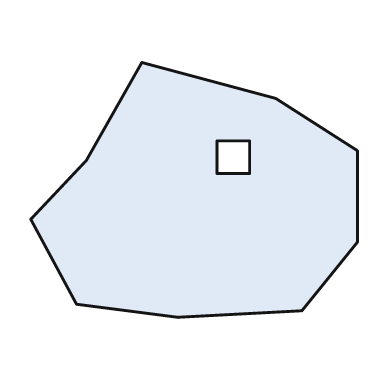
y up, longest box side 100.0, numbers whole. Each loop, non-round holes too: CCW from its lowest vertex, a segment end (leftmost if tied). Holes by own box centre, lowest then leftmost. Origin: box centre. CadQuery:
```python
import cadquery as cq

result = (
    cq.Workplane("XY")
    .moveTo(-5.0, -39.0)
    .lineTo(33.0, -37.0)
    .lineTo(50.0, -16.0)
    .lineTo(50.0, 12.0)
    .lineTo(25.0, 28.0)
    .lineTo(-16.0, 39.0)
    .lineTo(-33.0, 9.0)
    .lineTo(-50.0, -9.0)
    .lineTo(-36.0, -35.0)
    .close()
    .moveTo(7.0, 5.0)
    .lineTo(17.0, 5.0)
    .lineTo(17.0, 15.0)
    .lineTo(7.0, 15.0)
    .close()
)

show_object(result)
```